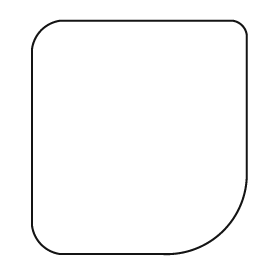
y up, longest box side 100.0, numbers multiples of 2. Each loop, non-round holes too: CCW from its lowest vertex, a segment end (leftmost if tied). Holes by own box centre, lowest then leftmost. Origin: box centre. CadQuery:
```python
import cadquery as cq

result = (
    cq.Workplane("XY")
    .moveTo(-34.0, -50.0)
    .lineTo(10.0, -50.0)
    .threePointArc((36.0, -40.0), (46.0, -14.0))
    .lineTo(46.0, 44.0)
    .threePointArc((44.0, 48.0), (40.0, 50.0))
    .lineTo(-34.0, 50.0)
    .threePointArc((-42.0, 46.0), (-46.0, 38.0))
    .lineTo(-46.0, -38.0)
    .threePointArc((-42.0, -46.0), (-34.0, -50.0))
    .close()
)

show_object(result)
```